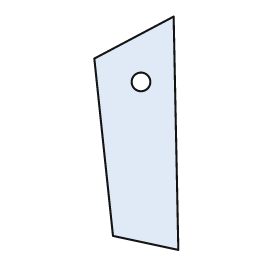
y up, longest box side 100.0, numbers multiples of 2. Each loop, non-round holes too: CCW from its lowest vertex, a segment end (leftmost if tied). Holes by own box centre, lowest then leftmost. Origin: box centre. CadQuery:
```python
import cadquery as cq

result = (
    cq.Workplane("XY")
    .moveTo(18.0, -50.0)
    .lineTo(16.0, 50.0)
    .lineTo(-18.0, 32.0)
    .lineTo(-10.0, -44.0)
    .close()
    .moveTo(2.0, 22.0)
    .circle(4.0)
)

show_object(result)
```